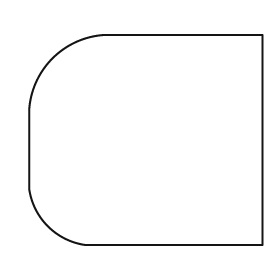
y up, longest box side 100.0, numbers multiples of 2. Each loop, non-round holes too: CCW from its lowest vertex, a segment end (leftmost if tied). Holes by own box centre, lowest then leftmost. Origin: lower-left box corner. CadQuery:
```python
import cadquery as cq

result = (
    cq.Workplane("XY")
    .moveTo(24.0, 0.0)
    .lineTo(100.0, 0.0)
    .lineTo(100.0, 90.0)
    .lineTo(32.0, 90.0)
    .threePointArc((10.0, 80.0), (0.0, 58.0))
    .lineTo(0.0, 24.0)
    .threePointArc((8.0, 8.0), (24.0, 0.0))
    .close()
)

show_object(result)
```